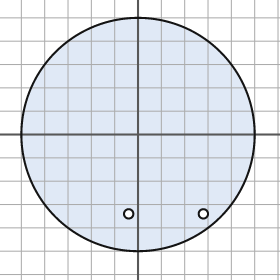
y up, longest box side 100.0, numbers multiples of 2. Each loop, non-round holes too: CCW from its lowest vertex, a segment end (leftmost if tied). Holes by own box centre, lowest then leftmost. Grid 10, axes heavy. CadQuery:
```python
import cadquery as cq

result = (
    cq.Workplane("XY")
    .moveTo(0.0, 0.0)
    .circle(50.0)
    .moveTo(-4.0, -34.0)
    .circle(2.0)
    .moveTo(28.0, -34.0)
    .circle(2.0)
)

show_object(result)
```